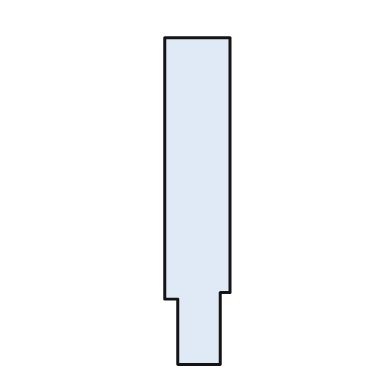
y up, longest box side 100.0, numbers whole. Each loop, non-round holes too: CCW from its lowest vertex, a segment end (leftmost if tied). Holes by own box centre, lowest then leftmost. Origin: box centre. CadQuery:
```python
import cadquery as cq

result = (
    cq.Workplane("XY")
    .moveTo(-6.0, -50.0)
    .lineTo(7.0, -50.0)
    .lineTo(7.0, -28.0)
    .lineTo(10.0, -28.0)
    .lineTo(10.0, 50.0)
    .lineTo(-10.0, 50.0)
    .lineTo(-10.0, -30.0)
    .lineTo(-6.0, -30.0)
    .close()
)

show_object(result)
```